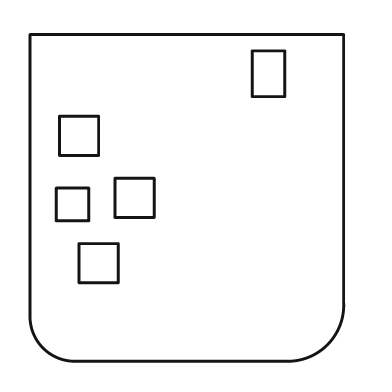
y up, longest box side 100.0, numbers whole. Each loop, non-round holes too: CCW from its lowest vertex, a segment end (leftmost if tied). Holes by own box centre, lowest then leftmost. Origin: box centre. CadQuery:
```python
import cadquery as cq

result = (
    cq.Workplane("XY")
    .moveTo(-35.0, -50.0)
    .lineTo(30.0, -50.0)
    .threePointArc((43.0, -45.0), (48.0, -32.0))
    .lineTo(48.0, 50.0)
    .lineTo(-48.0, 50.0)
    .lineTo(-48.0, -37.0)
    .threePointArc((-44.0, -46.0), (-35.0, -50.0))
    .close()
    .moveTo(-33.0, -26.0)
    .lineTo(-21.0, -26.0)
    .lineTo(-21.0, -14.0)
    .lineTo(-33.0, -14.0)
    .close()
    .moveTo(-40.0, -7.0)
    .lineTo(-30.0, -7.0)
    .lineTo(-30.0, 3.0)
    .lineTo(-40.0, 3.0)
    .close()
    .moveTo(-22.0, -6.0)
    .lineTo(-10.0, -6.0)
    .lineTo(-10.0, 6.0)
    .lineTo(-22.0, 6.0)
    .close()
    .moveTo(-39.0, 13.0)
    .lineTo(-27.0, 13.0)
    .lineTo(-27.0, 25.0)
    .lineTo(-39.0, 25.0)
    .close()
    .moveTo(20.0, 31.0)
    .lineTo(30.0, 31.0)
    .lineTo(30.0, 45.0)
    .lineTo(20.0, 45.0)
    .close()
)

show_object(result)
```